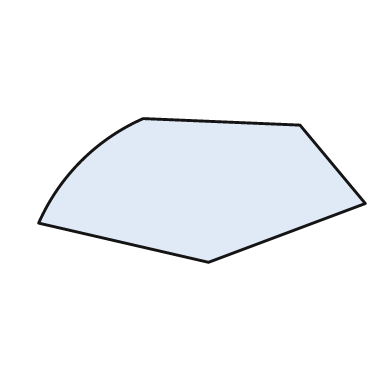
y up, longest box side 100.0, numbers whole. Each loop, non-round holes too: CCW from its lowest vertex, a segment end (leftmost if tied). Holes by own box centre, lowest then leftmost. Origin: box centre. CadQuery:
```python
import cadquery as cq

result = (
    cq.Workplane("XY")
    .moveTo(2.0, -22.0)
    .lineTo(50.0, -4.0)
    .lineTo(30.0, 20.0)
    .lineTo(-18.0, 22.0)
    .threePointArc((-37.0, 9.0), (-50.0, -10.0))
    .close()
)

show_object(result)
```